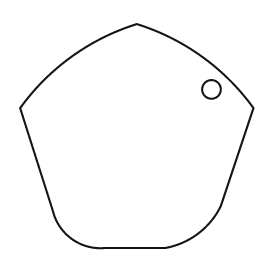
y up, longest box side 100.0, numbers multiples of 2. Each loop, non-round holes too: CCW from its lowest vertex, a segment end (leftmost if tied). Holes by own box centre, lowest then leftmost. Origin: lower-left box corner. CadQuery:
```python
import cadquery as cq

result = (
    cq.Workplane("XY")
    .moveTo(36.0, 0.0)
    .lineTo(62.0, 0.0)
    .threePointArc((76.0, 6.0), (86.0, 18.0))
    .lineTo(100.0, 60.0)
    .threePointArc((78.0, 82.0), (50.0, 96.0))
    .threePointArc((22.0, 82.0), (0.0, 60.0))
    .lineTo(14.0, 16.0)
    .threePointArc((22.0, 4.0), (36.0, 0.0))
    .close()
    .moveTo(82.0, 68.0)
    .circle(4.0)
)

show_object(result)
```